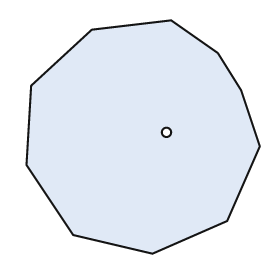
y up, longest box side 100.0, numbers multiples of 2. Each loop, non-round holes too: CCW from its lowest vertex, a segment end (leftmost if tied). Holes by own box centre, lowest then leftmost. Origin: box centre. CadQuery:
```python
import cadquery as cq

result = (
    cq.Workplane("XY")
    .moveTo(4.0, -50.0)
    .lineTo(36.0, -36.0)
    .lineTo(50.0, -4.0)
    .lineTo(42.0, 20.0)
    .lineTo(32.0, 36.0)
    .lineTo(12.0, 50.0)
    .lineTo(-22.0, 46.0)
    .lineTo(-48.0, 22.0)
    .lineTo(-50.0, -12.0)
    .lineTo(-30.0, -42.0)
    .close()
    .moveTo(10.0, 2.0)
    .circle(2.0)
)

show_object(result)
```